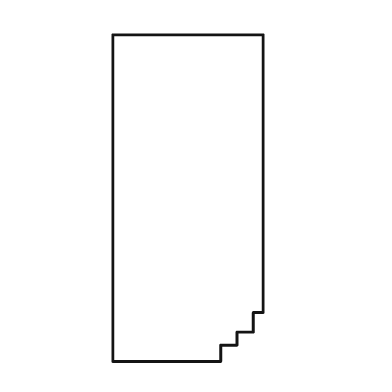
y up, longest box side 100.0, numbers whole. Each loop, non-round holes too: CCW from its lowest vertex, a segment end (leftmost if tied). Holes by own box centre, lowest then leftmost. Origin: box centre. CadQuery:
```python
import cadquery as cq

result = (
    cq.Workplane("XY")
    .moveTo(-23.0, -50.0)
    .lineTo(10.0, -50.0)
    .lineTo(10.0, -45.0)
    .lineTo(15.0, -45.0)
    .lineTo(15.0, -41.0)
    .lineTo(20.0, -41.0)
    .lineTo(20.0, -35.0)
    .lineTo(23.0, -35.0)
    .lineTo(23.0, 50.0)
    .lineTo(-23.0, 50.0)
    .close()
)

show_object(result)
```